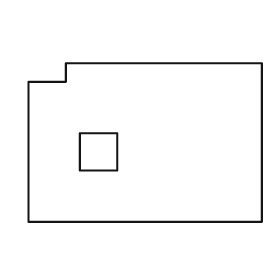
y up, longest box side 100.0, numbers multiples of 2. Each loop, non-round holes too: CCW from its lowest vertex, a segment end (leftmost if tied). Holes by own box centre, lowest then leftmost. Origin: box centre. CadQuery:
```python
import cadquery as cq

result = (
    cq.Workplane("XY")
    .moveTo(-50.0, -34.0)
    .lineTo(50.0, -34.0)
    .lineTo(50.0, 34.0)
    .lineTo(-34.0, 34.0)
    .lineTo(-34.0, 26.0)
    .lineTo(-50.0, 26.0)
    .close()
    .moveTo(-28.0, -12.0)
    .lineTo(-12.0, -12.0)
    .lineTo(-12.0, 4.0)
    .lineTo(-28.0, 4.0)
    .close()
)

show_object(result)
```